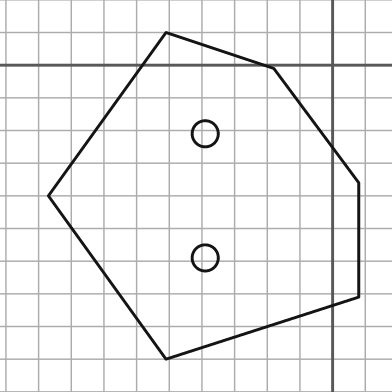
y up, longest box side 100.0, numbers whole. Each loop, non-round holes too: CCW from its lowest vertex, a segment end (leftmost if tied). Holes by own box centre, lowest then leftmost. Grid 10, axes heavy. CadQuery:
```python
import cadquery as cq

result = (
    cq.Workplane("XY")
    .moveTo(-51.0, -90.0)
    .lineTo(8.0, -71.0)
    .lineTo(8.0, -36.0)
    .lineTo(-18.0, -1.0)
    .lineTo(-51.0, 10.0)
    .lineTo(-87.0, -40.0)
    .close()
    .moveTo(-39.0, -59.0)
    .circle(4.0)
    .moveTo(-39.0, -21.0)
    .circle(4.0)
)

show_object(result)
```